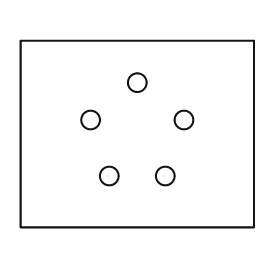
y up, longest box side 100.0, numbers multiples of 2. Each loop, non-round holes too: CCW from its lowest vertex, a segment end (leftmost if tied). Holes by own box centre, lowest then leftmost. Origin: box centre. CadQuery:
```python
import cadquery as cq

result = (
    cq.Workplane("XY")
    .moveTo(-50.0, -40.0)
    .lineTo(50.0, -40.0)
    .lineTo(50.0, 40.0)
    .lineTo(-50.0, 40.0)
    .close()
    .moveTo(-12.0, -18.0)
    .circle(4.0)
    .moveTo(12.0, -18.0)
    .circle(4.0)
    .moveTo(-20.0, 6.0)
    .circle(4.0)
    .moveTo(20.0, 6.0)
    .circle(4.0)
    .moveTo(0.0, 22.0)
    .circle(4.0)
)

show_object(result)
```